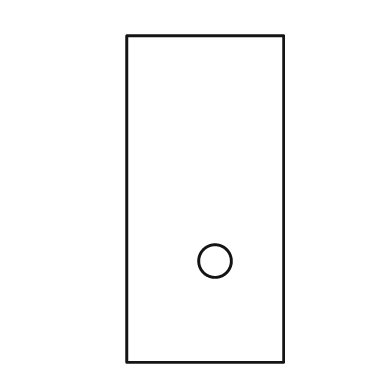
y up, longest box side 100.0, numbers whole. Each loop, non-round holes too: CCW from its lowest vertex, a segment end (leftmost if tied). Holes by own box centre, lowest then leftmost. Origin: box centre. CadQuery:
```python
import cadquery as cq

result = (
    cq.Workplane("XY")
    .moveTo(-24.0, -50.0)
    .lineTo(24.0, -50.0)
    .lineTo(24.0, 50.0)
    .lineTo(-24.0, 50.0)
    .close()
    .moveTo(3.0, -19.0)
    .circle(5.0)
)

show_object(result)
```